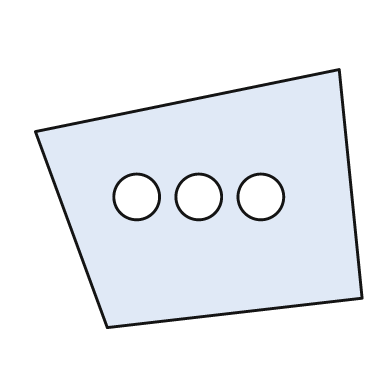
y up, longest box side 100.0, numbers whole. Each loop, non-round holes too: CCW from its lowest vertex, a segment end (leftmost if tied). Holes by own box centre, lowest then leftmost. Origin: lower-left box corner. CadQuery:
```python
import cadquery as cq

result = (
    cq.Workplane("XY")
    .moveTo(22.0, 0.0)
    .lineTo(100.0, 9.0)
    .lineTo(93.0, 79.0)
    .lineTo(0.0, 60.0)
    .close()
    .moveTo(31.0, 40.0)
    .circle(7.0)
    .moveTo(50.0, 40.0)
    .circle(7.0)
    .moveTo(69.0, 40.0)
    .circle(7.0)
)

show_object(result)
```